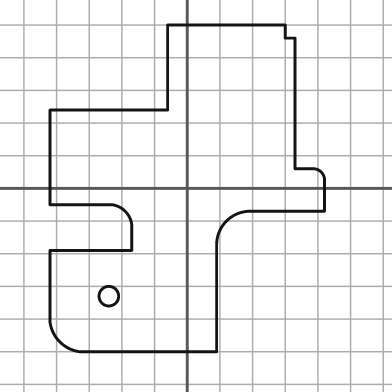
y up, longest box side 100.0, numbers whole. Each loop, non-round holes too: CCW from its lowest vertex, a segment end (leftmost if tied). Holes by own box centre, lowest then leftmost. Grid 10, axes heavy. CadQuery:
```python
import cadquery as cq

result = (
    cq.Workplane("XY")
    .moveTo(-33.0, -50.0)
    .lineTo(9.0, -50.0)
    .lineTo(9.0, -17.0)
    .threePointArc((12.0, -10.0), (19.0, -7.0))
    .lineTo(42.0, -7.0)
    .lineTo(42.0, 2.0)
    .threePointArc((41.0, 5.0), (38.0, 6.0))
    .lineTo(33.0, 6.0)
    .lineTo(33.0, 46.0)
    .lineTo(30.0, 46.0)
    .lineTo(30.0, 50.0)
    .lineTo(-6.0, 50.0)
    .lineTo(-6.0, 24.0)
    .lineTo(-42.0, 24.0)
    .lineTo(-42.0, -5.0)
    .lineTo(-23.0, -5.0)
    .threePointArc((-19.0, -7.0), (-17.0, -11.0))
    .lineTo(-17.0, -19.0)
    .lineTo(-42.0, -19.0)
    .lineTo(-42.0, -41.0)
    .threePointArc((-39.0, -47.0), (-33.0, -50.0))
    .close()
    .moveTo(-24.0, -33.0)
    .circle(3.0)
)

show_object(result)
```